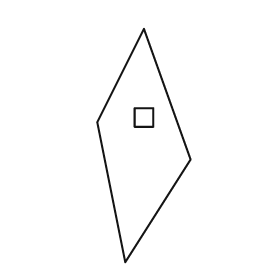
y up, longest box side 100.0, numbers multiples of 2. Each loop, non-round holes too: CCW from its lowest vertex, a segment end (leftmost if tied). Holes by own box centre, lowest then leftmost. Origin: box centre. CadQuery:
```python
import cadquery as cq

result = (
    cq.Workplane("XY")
    .moveTo(-8.0, -50.0)
    .lineTo(20.0, -6.0)
    .lineTo(0.0, 50.0)
    .lineTo(-20.0, 10.0)
    .close()
    .moveTo(-4.0, 8.0)
    .lineTo(4.0, 8.0)
    .lineTo(4.0, 16.0)
    .lineTo(-4.0, 16.0)
    .close()
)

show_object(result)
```